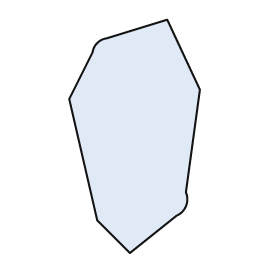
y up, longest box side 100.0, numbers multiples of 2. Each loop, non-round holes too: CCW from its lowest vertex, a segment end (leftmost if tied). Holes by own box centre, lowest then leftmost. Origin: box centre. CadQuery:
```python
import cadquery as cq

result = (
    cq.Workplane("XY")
    .moveTo(-2.0, -50.0)
    .lineTo(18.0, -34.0)
    .threePointArc((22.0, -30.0), (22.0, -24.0))
    .lineTo(28.0, 20.0)
    .lineTo(14.0, 50.0)
    .lineTo(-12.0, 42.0)
    .threePointArc((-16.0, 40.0), (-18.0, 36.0))
    .lineTo(-28.0, 16.0)
    .lineTo(-16.0, -36.0)
    .close()
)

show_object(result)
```